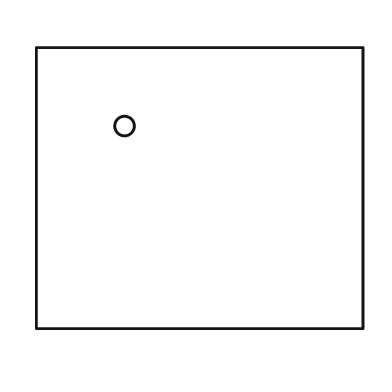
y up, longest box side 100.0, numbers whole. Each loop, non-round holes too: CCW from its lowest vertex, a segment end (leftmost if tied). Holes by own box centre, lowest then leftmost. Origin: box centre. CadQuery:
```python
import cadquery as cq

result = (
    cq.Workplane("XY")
    .moveTo(-50.0, -43.0)
    .lineTo(50.0, -43.0)
    .lineTo(50.0, 43.0)
    .lineTo(-50.0, 43.0)
    .close()
    .moveTo(-23.0, 19.0)
    .circle(3.0)
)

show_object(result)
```